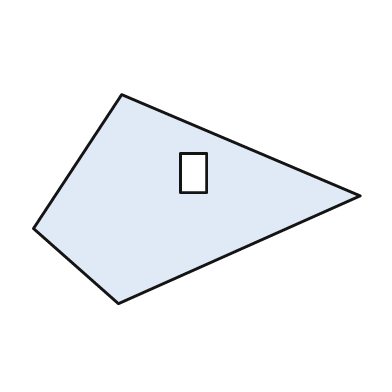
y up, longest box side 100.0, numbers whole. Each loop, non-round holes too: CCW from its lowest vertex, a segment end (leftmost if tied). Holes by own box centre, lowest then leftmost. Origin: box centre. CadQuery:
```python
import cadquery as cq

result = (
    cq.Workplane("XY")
    .moveTo(-24.0, -32.0)
    .lineTo(50.0, 1.0)
    .lineTo(-23.0, 32.0)
    .lineTo(-50.0, -9.0)
    .close()
    .moveTo(-5.0, 2.0)
    .lineTo(3.0, 2.0)
    .lineTo(3.0, 14.0)
    .lineTo(-5.0, 14.0)
    .close()
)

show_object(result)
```